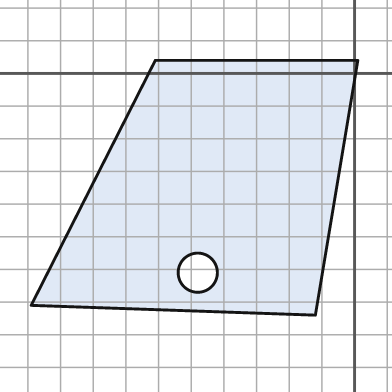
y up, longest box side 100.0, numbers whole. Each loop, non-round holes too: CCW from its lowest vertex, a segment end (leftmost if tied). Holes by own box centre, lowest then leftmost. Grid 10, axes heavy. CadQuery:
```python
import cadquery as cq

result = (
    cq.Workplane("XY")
    .moveTo(-12.0, -74.0)
    .lineTo(1.0, 4.0)
    .lineTo(-61.0, 4.0)
    .lineTo(-99.0, -71.0)
    .close()
    .moveTo(-48.0, -61.0)
    .circle(6.0)
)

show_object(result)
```